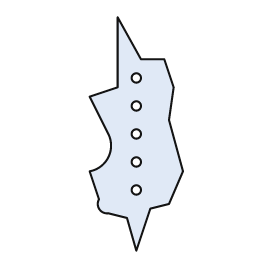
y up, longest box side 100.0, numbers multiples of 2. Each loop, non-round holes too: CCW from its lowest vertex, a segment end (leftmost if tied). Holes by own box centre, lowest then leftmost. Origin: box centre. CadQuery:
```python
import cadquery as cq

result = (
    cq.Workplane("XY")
    .moveTo(0.0, -50.0)
    .lineTo(6.0, -32.0)
    .lineTo(14.0, -30.0)
    .lineTo(20.0, -16.0)
    .lineTo(14.0, 6.0)
    .lineTo(16.0, 20.0)
    .lineTo(12.0, 32.0)
    .lineTo(2.0, 32.0)
    .lineTo(-8.0, 50.0)
    .lineTo(-8.0, 20.0)
    .lineTo(-20.0, 16.0)
    .lineTo(-12.0, 0.0)
    .threePointArc((-12.0, -10.0), (-20.0, -16.0))
    .lineTo(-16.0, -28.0)
    .threePointArc((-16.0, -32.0), (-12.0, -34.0))
    .lineTo(-4.0, -36.0)
    .close()
    .moveTo(0.0, -24.0)
    .circle(2.0)
    .moveTo(0.0, -12.0)
    .circle(2.0)
    .moveTo(0.0, 0.0)
    .circle(2.0)
    .moveTo(0.0, 12.0)
    .circle(2.0)
    .moveTo(0.0, 24.0)
    .circle(2.0)
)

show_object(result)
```